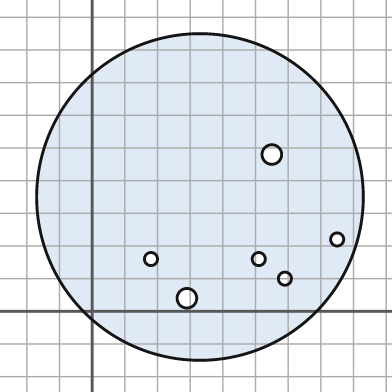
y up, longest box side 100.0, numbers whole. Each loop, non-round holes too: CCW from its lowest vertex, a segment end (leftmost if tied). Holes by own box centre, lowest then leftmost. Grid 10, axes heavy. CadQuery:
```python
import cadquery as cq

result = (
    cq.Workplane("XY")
    .moveTo(33.0, 35.0)
    .circle(50.0)
    .moveTo(29.0, 4.0)
    .circle(3.0)
    .moveTo(59.0, 10.0)
    .circle(2.0)
    .moveTo(18.0, 16.0)
    .circle(2.0)
    .moveTo(51.0, 16.0)
    .circle(2.0)
    .moveTo(75.0, 22.0)
    .circle(2.0)
    .moveTo(55.0, 48.0)
    .circle(3.0)
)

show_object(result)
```